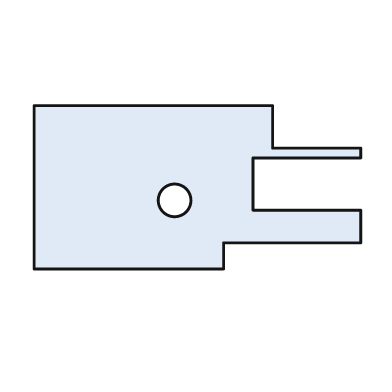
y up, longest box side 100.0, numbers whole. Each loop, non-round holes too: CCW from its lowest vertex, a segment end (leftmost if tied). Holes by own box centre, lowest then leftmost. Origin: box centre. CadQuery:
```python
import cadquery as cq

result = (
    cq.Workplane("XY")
    .moveTo(-50.0, -25.0)
    .lineTo(8.0, -25.0)
    .lineTo(8.0, -17.0)
    .lineTo(50.0, -17.0)
    .lineTo(50.0, -7.0)
    .lineTo(17.0, -7.0)
    .lineTo(17.0, 9.0)
    .lineTo(50.0, 9.0)
    .lineTo(50.0, 12.0)
    .lineTo(23.0, 12.0)
    .lineTo(23.0, 25.0)
    .lineTo(-50.0, 25.0)
    .close()
    .moveTo(-7.0, -4.0)
    .circle(5.0)
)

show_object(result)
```